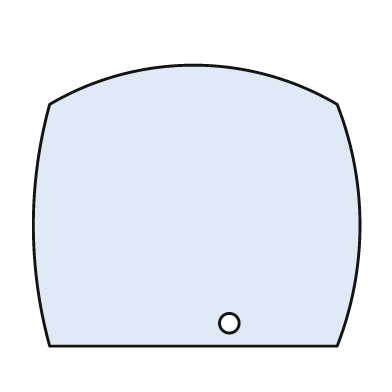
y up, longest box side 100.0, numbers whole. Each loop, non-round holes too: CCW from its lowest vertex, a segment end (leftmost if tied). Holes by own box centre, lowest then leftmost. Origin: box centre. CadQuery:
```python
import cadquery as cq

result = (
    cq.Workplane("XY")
    .moveTo(-45.0, -43.0)
    .lineTo(43.0, -43.0)
    .threePointArc((50.0, -6.0), (43.0, 31.0))
    .threePointArc((-1.0, 43.0), (-45.0, 31.0))
    .threePointArc((-50.0, -6.0), (-45.0, -43.0))
    .close()
    .moveTo(10.0, -36.0)
    .circle(3.0)
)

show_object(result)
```